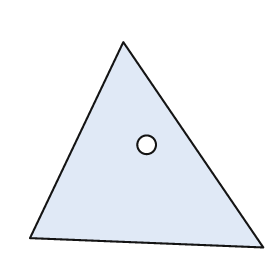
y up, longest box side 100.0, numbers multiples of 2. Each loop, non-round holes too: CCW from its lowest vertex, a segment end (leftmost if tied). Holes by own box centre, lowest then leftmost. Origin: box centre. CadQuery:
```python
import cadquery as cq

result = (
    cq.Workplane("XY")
    .moveTo(50.0, -44.0)
    .lineTo(-10.0, 44.0)
    .lineTo(-50.0, -40.0)
    .close()
    .moveTo(0.0, 0.0)
    .circle(4.0)
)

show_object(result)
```